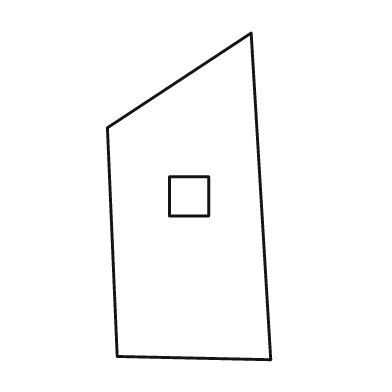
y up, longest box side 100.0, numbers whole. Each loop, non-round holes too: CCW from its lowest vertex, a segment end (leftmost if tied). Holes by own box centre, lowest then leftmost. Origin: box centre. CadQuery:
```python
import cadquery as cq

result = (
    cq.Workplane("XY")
    .moveTo(25.0, -50.0)
    .lineTo(19.0, 50.0)
    .lineTo(-25.0, 21.0)
    .lineTo(-22.0, -49.0)
    .close()
    .moveTo(-6.0, -6.0)
    .lineTo(6.0, -6.0)
    .lineTo(6.0, 6.0)
    .lineTo(-6.0, 6.0)
    .close()
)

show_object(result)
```